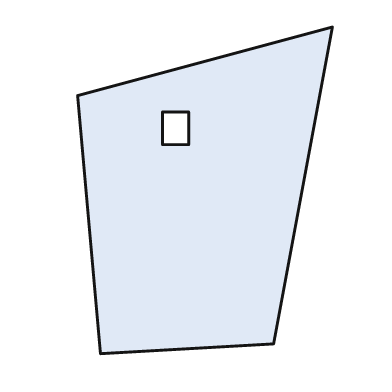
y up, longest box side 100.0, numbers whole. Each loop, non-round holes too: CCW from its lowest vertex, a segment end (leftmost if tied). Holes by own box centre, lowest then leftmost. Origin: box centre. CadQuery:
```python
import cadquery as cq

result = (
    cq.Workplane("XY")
    .moveTo(-32.0, -50.0)
    .lineTo(21.0, -47.0)
    .lineTo(39.0, 50.0)
    .lineTo(-39.0, 29.0)
    .close()
    .moveTo(-13.0, 14.0)
    .lineTo(-5.0, 14.0)
    .lineTo(-5.0, 24.0)
    .lineTo(-13.0, 24.0)
    .close()
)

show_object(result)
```